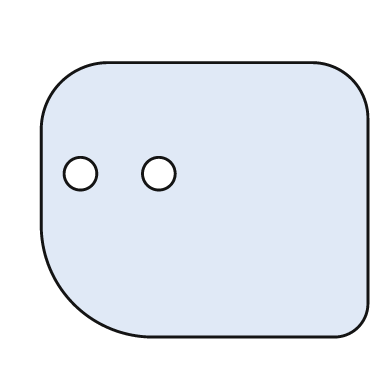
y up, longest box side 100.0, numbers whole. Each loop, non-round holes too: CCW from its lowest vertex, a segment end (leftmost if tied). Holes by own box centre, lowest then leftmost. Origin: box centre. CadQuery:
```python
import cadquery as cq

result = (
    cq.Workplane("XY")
    .moveTo(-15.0, -42.0)
    .lineTo(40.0, -42.0)
    .threePointArc((47.0, -39.0), (50.0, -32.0))
    .lineTo(50.0, 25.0)
    .threePointArc((45.0, 37.0), (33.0, 42.0))
    .lineTo(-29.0, 42.0)
    .threePointArc((-44.0, 36.0), (-50.0, 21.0))
    .lineTo(-50.0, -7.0)
    .threePointArc((-40.0, -32.0), (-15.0, -42.0))
    .close()
    .moveTo(-38.0, 8.0)
    .circle(5.0)
    .moveTo(-14.0, 8.0)
    .circle(5.0)
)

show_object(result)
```